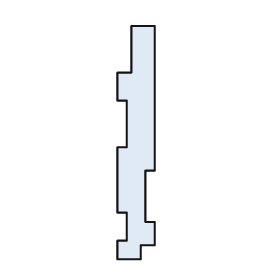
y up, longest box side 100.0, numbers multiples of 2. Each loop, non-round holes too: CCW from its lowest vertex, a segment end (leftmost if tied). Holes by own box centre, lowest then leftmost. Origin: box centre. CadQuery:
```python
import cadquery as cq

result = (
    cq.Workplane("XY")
    .moveTo(-8.0, -50.0)
    .lineTo(2.0, -50.0)
    .lineTo(2.0, -44.0)
    .lineTo(8.0, -44.0)
    .lineTo(8.0, -34.0)
    .lineTo(4.0, -34.0)
    .lineTo(4.0, -12.0)
    .lineTo(8.0, -12.0)
    .lineTo(8.0, 50.0)
    .lineTo(-2.0, 50.0)
    .lineTo(-2.0, 30.0)
    .lineTo(-8.0, 30.0)
    .lineTo(-8.0, 18.0)
    .lineTo(-4.0, 18.0)
    .lineTo(-4.0, -2.0)
    .lineTo(-8.0, -2.0)
    .lineTo(-8.0, -30.0)
    .lineTo(-4.0, -30.0)
    .lineTo(-4.0, -42.0)
    .lineTo(-8.0, -42.0)
    .close()
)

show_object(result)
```